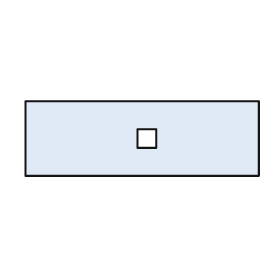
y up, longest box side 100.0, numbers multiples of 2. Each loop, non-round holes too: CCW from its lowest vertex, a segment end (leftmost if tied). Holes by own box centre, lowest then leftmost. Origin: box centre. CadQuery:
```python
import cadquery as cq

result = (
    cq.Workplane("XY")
    .moveTo(-50.0, -16.0)
    .lineTo(50.0, -16.0)
    .lineTo(50.0, 16.0)
    .lineTo(-50.0, 16.0)
    .close()
    .moveTo(-2.0, -4.0)
    .lineTo(6.0, -4.0)
    .lineTo(6.0, 4.0)
    .lineTo(-2.0, 4.0)
    .close()
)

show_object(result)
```